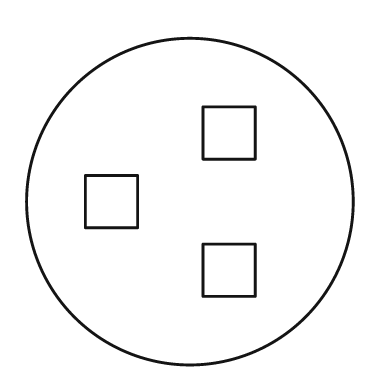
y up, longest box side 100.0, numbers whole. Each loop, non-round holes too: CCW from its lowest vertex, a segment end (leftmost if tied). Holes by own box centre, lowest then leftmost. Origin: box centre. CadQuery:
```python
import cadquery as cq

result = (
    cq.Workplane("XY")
    .moveTo(0.0, 0.0)
    .circle(50.0)
    .moveTo(4.0, -29.0)
    .lineTo(20.0, -29.0)
    .lineTo(20.0, -13.0)
    .lineTo(4.0, -13.0)
    .close()
    .moveTo(-32.0, -8.0)
    .lineTo(-16.0, -8.0)
    .lineTo(-16.0, 8.0)
    .lineTo(-32.0, 8.0)
    .close()
    .moveTo(4.0, 13.0)
    .lineTo(20.0, 13.0)
    .lineTo(20.0, 29.0)
    .lineTo(4.0, 29.0)
    .close()
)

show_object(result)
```